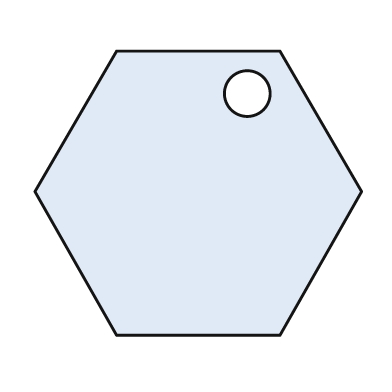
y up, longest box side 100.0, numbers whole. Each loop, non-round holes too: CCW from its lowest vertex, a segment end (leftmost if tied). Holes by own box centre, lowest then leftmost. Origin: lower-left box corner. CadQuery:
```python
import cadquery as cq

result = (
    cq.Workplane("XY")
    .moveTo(25.0, 0.0)
    .lineTo(75.0, 0.0)
    .lineTo(100.0, 44.0)
    .lineTo(75.0, 87.0)
    .lineTo(25.0, 87.0)
    .lineTo(0.0, 44.0)
    .close()
    .moveTo(65.0, 74.0)
    .circle(7.0)
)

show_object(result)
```